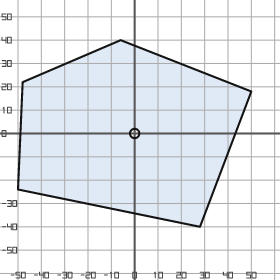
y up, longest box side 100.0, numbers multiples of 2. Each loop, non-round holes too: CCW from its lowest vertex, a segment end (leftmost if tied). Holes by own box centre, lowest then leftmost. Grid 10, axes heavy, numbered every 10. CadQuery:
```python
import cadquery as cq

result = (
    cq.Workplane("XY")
    .moveTo(28.0, -40.0)
    .lineTo(50.0, 18.0)
    .lineTo(-6.0, 40.0)
    .lineTo(-48.0, 22.0)
    .lineTo(-50.0, -24.0)
    .close()
    .moveTo(0.0, 0.0)
    .circle(2.0)
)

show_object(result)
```